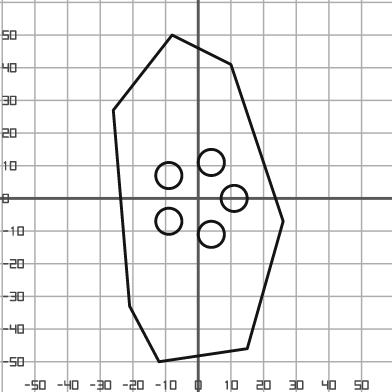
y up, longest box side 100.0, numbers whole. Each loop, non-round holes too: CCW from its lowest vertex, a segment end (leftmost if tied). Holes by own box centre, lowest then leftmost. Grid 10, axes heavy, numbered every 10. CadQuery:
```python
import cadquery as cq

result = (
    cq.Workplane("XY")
    .moveTo(-12.0, -50.0)
    .lineTo(15.0, -46.0)
    .lineTo(26.0, -7.0)
    .lineTo(10.0, 41.0)
    .lineTo(-8.0, 50.0)
    .lineTo(-26.0, 27.0)
    .lineTo(-21.0, -33.0)
    .close()
    .moveTo(4.0, -11.0)
    .circle(4.0)
    .moveTo(-9.0, -7.0)
    .circle(4.0)
    .moveTo(11.0, 0.0)
    .circle(4.0)
    .moveTo(-9.0, 7.0)
    .circle(4.0)
    .moveTo(4.0, 11.0)
    .circle(4.0)
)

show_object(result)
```